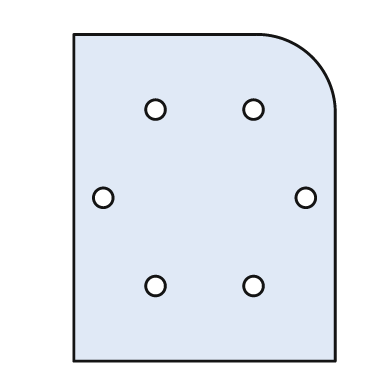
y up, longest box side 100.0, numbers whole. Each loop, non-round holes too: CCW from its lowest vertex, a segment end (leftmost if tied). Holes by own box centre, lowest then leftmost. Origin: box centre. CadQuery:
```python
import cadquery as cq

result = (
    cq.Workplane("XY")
    .moveTo(-40.0, -50.0)
    .lineTo(40.0, -50.0)
    .lineTo(40.0, 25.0)
    .threePointArc((33.0, 43.0), (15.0, 50.0))
    .lineTo(-40.0, 50.0)
    .close()
    .moveTo(-15.0, -27.0)
    .circle(3.0)
    .moveTo(15.0, -27.0)
    .circle(3.0)
    .moveTo(-31.0, 0.0)
    .circle(3.0)
    .moveTo(31.0, 0.0)
    .circle(3.0)
    .moveTo(-15.0, 27.0)
    .circle(3.0)
    .moveTo(15.0, 27.0)
    .circle(3.0)
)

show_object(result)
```